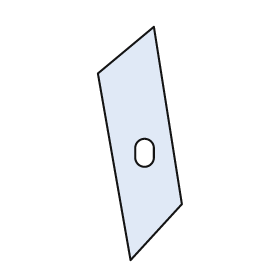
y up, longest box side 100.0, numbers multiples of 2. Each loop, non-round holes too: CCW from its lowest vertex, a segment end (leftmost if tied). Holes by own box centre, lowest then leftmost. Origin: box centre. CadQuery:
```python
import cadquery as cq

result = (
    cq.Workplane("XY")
    .moveTo(-4.0, -50.0)
    .lineTo(18.0, -26.0)
    .lineTo(6.0, 50.0)
    .lineTo(-18.0, 30.0)
    .close()
    .moveTo(-2.0, -6.0)
    .threePointArc((2.0, -10.0), (6.0, -6.0))
    .lineTo(6.0, -2.0)
    .threePointArc((2.0, 2.0), (-2.0, -2.0))
    .close()
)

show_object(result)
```